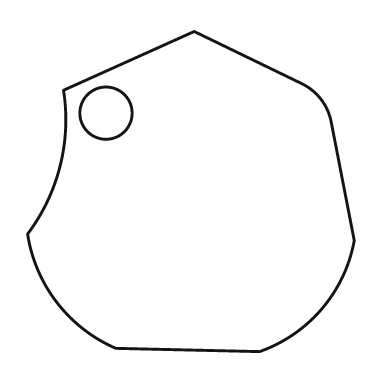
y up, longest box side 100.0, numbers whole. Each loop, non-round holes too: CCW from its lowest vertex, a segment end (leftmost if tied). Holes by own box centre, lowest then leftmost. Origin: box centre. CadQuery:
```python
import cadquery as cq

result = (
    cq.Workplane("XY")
    .moveTo(21.0, -49.0)
    .threePointArc((40.0, -36.0), (50.0, -15.0))
    .lineTo(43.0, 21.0)
    .threePointArc((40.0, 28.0), (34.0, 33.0))
    .lineTo(1.0, 49.0)
    .lineTo(-39.0, 31.0)
    .threePointArc((-40.0, 8.0), (-50.0, -13.0))
    .threePointArc((-41.0, -34.0), (-23.0, -48.0))
    .close()
    .moveTo(-26.0, 24.0)
    .circle(8.0)
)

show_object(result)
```